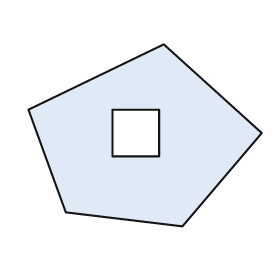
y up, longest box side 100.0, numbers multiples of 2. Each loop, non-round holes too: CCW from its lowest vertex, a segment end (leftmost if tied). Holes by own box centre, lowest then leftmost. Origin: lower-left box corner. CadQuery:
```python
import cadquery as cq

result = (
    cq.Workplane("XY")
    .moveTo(66.0, 0.0)
    .lineTo(100.0, 40.0)
    .lineTo(58.0, 78.0)
    .lineTo(0.0, 50.0)
    .lineTo(16.0, 6.0)
    .close()
    .moveTo(36.0, 30.0)
    .lineTo(56.0, 30.0)
    .lineTo(56.0, 50.0)
    .lineTo(36.0, 50.0)
    .close()
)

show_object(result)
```